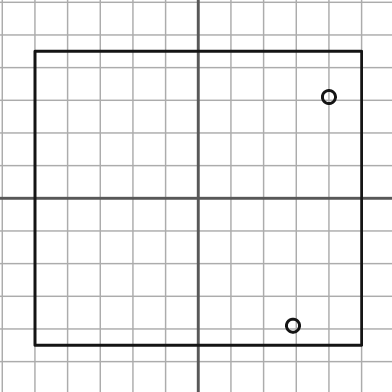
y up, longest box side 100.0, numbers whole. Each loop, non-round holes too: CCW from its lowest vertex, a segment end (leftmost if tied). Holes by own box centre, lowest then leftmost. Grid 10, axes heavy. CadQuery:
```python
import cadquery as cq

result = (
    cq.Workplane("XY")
    .moveTo(-50.0, -45.0)
    .lineTo(50.0, -45.0)
    .lineTo(50.0, 45.0)
    .lineTo(-50.0, 45.0)
    .close()
    .moveTo(29.0, -39.0)
    .circle(2.0)
    .moveTo(40.0, 31.0)
    .circle(2.0)
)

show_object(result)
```